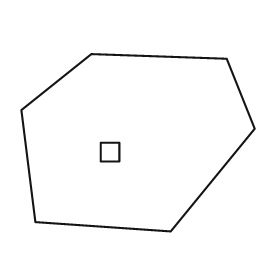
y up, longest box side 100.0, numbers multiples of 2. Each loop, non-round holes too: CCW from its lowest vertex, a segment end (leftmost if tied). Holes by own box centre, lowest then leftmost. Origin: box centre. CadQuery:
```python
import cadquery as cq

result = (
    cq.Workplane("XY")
    .moveTo(14.0, -38.0)
    .lineTo(50.0, 6.0)
    .lineTo(38.0, 36.0)
    .lineTo(-20.0, 38.0)
    .lineTo(-50.0, 14.0)
    .lineTo(-44.0, -34.0)
    .close()
    .moveTo(-16.0, -8.0)
    .lineTo(-8.0, -8.0)
    .lineTo(-8.0, 0.0)
    .lineTo(-16.0, 0.0)
    .close()
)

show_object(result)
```